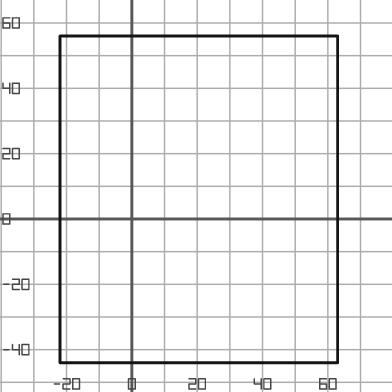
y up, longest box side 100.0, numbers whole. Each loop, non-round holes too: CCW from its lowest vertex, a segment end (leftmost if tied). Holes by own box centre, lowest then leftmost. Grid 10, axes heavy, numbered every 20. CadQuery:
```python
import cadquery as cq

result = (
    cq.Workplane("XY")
    .moveTo(-22.0, -44.0)
    .lineTo(63.0, -44.0)
    .lineTo(63.0, 56.0)
    .lineTo(-22.0, 56.0)
    .close()
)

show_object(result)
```